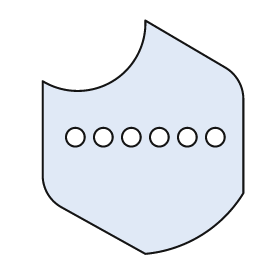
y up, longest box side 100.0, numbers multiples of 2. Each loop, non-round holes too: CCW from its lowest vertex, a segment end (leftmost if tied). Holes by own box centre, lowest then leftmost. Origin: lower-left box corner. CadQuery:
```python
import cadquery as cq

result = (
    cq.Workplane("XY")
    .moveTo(44.0, 0.0)
    .threePointArc((68.0, 8.0), (86.0, 26.0))
    .lineTo(86.0, 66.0)
    .threePointArc((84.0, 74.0), (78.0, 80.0))
    .lineTo(44.0, 100.0)
    .threePointArc((30.0, 74.0), (0.0, 74.0))
    .lineTo(0.0, 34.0)
    .threePointArc((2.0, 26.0), (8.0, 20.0))
    .close()
    .moveTo(14.0, 50.0)
    .circle(4.0)
    .moveTo(26.0, 50.0)
    .circle(4.0)
    .moveTo(38.0, 50.0)
    .circle(4.0)
    .moveTo(50.0, 50.0)
    .circle(4.0)
    .moveTo(62.0, 50.0)
    .circle(4.0)
    .moveTo(74.0, 50.0)
    .circle(4.0)
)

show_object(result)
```